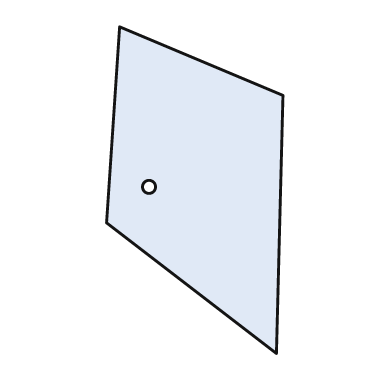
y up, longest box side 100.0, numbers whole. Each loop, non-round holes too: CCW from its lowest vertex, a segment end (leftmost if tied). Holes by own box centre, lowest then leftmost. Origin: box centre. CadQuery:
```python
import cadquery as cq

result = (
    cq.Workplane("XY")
    .moveTo(25.0, -50.0)
    .lineTo(27.0, 29.0)
    .lineTo(-23.0, 50.0)
    .lineTo(-27.0, -10.0)
    .close()
    .moveTo(-14.0, 1.0)
    .circle(2.0)
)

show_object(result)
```